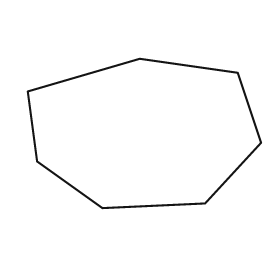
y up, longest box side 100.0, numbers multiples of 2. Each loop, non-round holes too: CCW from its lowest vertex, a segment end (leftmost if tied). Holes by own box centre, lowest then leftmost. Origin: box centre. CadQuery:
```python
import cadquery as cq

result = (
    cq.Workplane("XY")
    .moveTo(-18.0, -32.0)
    .lineTo(26.0, -30.0)
    .lineTo(50.0, -4.0)
    .lineTo(40.0, 26.0)
    .lineTo(-2.0, 32.0)
    .lineTo(-50.0, 18.0)
    .lineTo(-46.0, -12.0)
    .close()
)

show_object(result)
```